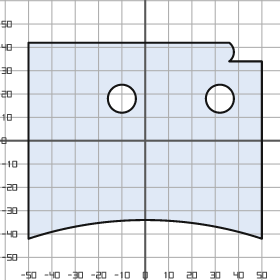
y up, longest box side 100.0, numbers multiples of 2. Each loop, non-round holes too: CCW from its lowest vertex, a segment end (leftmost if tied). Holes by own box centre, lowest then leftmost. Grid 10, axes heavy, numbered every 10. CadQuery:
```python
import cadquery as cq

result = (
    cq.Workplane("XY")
    .moveTo(-50.0, -42.0)
    .threePointArc((0.0, -34.0), (50.0, -42.0))
    .lineTo(50.0, 34.0)
    .lineTo(36.0, 34.0)
    .threePointArc((38.0, 38.0), (36.0, 42.0))
    .lineTo(-50.0, 42.0)
    .close()
    .moveTo(-10.0, 18.0)
    .circle(6.0)
    .moveTo(32.0, 18.0)
    .circle(6.0)
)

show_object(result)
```